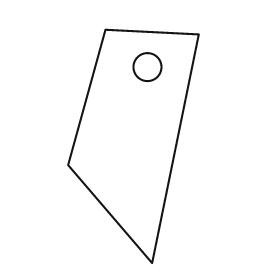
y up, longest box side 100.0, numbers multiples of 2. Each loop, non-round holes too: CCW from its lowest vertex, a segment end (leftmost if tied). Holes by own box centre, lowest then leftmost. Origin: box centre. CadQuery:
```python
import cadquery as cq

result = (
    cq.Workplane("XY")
    .moveTo(8.0, -50.0)
    .lineTo(28.0, 48.0)
    .lineTo(-12.0, 50.0)
    .lineTo(-28.0, -8.0)
    .close()
    .moveTo(6.0, 34.0)
    .circle(6.0)
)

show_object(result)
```